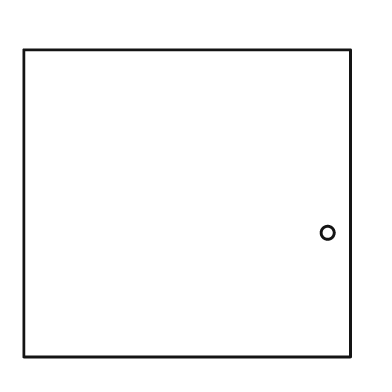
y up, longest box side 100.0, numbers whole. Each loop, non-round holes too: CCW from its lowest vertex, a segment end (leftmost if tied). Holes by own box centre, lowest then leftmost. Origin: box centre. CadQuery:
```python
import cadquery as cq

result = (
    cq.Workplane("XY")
    .moveTo(-50.0, -47.0)
    .lineTo(50.0, -47.0)
    .lineTo(50.0, 47.0)
    .lineTo(-50.0, 47.0)
    .close()
    .moveTo(43.0, -9.0)
    .circle(2.0)
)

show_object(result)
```